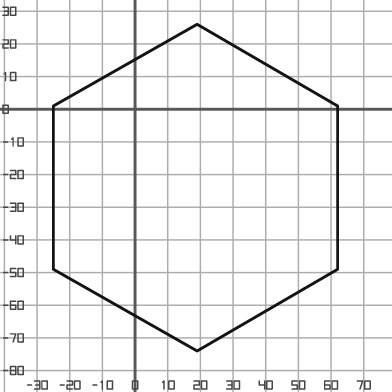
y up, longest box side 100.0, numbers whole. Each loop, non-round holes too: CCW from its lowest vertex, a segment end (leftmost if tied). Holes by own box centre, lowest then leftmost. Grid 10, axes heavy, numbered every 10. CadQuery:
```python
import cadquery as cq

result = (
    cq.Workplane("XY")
    .moveTo(19.0, -74.0)
    .lineTo(62.0, -49.0)
    .lineTo(62.0, 1.0)
    .lineTo(19.0, 26.0)
    .lineTo(-25.0, 1.0)
    .lineTo(-25.0, -49.0)
    .close()
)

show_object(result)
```